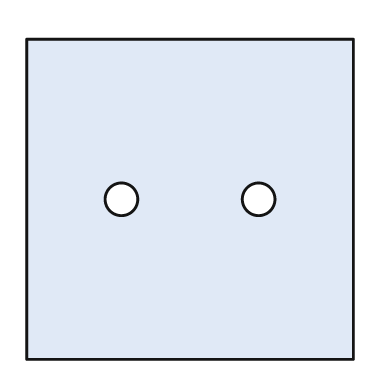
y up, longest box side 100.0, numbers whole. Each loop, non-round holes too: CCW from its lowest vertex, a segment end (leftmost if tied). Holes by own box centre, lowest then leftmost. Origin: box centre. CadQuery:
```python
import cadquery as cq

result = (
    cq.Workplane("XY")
    .moveTo(-50.0, -49.0)
    .lineTo(50.0, -49.0)
    .lineTo(50.0, 49.0)
    .lineTo(-50.0, 49.0)
    .close()
    .moveTo(-21.0, 0.0)
    .circle(5.0)
    .moveTo(21.0, 0.0)
    .circle(5.0)
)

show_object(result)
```